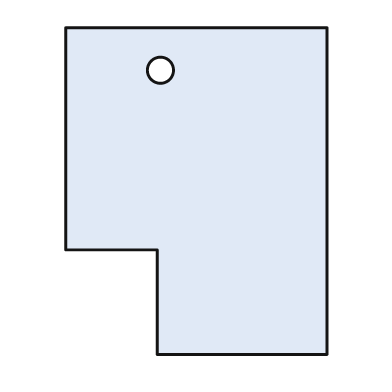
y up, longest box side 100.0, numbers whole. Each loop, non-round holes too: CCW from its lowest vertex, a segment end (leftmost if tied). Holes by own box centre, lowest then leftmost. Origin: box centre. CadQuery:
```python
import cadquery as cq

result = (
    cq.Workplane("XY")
    .moveTo(-12.0, -50.0)
    .lineTo(40.0, -50.0)
    .lineTo(40.0, 50.0)
    .lineTo(-40.0, 50.0)
    .lineTo(-40.0, -18.0)
    .lineTo(-12.0, -18.0)
    .close()
    .moveTo(-11.0, 37.0)
    .circle(4.0)
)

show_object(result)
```